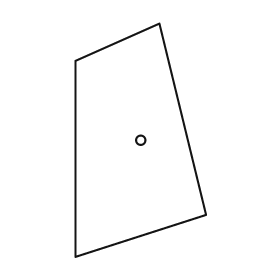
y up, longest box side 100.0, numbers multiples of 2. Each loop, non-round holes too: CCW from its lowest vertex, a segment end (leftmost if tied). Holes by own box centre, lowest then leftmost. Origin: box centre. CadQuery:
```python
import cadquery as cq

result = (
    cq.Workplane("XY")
    .moveTo(-28.0, -50.0)
    .lineTo(28.0, -32.0)
    .lineTo(8.0, 50.0)
    .lineTo(-28.0, 34.0)
    .close()
    .moveTo(0.0, 0.0)
    .circle(2.0)
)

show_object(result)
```